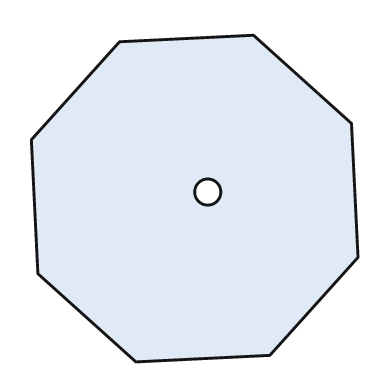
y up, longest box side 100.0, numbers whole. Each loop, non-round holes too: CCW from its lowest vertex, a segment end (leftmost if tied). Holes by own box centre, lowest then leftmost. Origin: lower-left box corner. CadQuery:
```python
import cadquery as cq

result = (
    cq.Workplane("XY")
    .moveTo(32.0, 0.0)
    .lineTo(73.0, 2.0)
    .lineTo(100.0, 32.0)
    .lineTo(98.0, 73.0)
    .lineTo(68.0, 100.0)
    .lineTo(27.0, 98.0)
    .lineTo(0.0, 68.0)
    .lineTo(2.0, 27.0)
    .close()
    .moveTo(54.0, 52.0)
    .circle(4.0)
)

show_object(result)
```